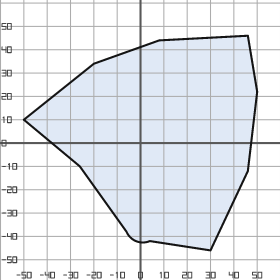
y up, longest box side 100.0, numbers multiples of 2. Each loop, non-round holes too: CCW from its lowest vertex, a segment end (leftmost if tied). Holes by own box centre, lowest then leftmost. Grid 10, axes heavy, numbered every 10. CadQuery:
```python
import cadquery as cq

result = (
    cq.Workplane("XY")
    .moveTo(30.0, -46.0)
    .lineTo(46.0, -12.0)
    .lineTo(50.0, 22.0)
    .lineTo(46.0, 46.0)
    .lineTo(8.0, 44.0)
    .lineTo(-20.0, 34.0)
    .lineTo(-50.0, 10.0)
    .lineTo(-26.0, -10.0)
    .lineTo(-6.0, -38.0)
    .threePointArc((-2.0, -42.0), (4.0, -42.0))
    .close()
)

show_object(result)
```